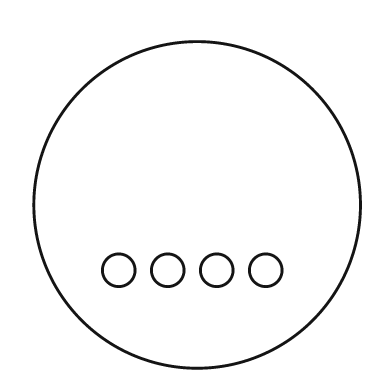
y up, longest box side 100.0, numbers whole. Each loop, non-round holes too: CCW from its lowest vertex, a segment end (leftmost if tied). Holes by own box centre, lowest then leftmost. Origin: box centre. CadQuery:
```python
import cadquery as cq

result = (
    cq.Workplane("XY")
    .moveTo(0.0, 0.0)
    .circle(50.0)
    .moveTo(-24.0, -20.0)
    .circle(5.0)
    .moveTo(-9.0, -20.0)
    .circle(5.0)
    .moveTo(6.0, -20.0)
    .circle(5.0)
    .moveTo(21.0, -20.0)
    .circle(5.0)
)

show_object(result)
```